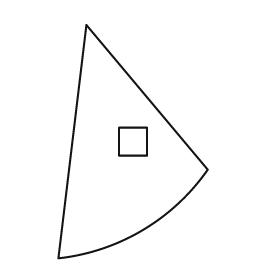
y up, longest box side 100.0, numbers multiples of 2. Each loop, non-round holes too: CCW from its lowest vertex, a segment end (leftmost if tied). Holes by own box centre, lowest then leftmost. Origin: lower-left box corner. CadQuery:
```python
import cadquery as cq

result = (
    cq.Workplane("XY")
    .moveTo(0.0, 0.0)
    .threePointArc((36.0, 12.0), (64.0, 38.0))
    .lineTo(12.0, 100.0)
    .close()
    .moveTo(26.0, 44.0)
    .lineTo(38.0, 44.0)
    .lineTo(38.0, 56.0)
    .lineTo(26.0, 56.0)
    .close()
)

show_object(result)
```